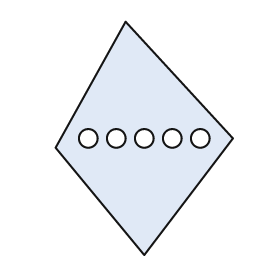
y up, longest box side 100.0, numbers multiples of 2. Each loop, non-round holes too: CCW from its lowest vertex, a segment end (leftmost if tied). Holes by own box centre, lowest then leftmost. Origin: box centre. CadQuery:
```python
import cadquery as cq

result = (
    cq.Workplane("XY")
    .moveTo(0.0, -50.0)
    .lineTo(38.0, 0.0)
    .lineTo(-8.0, 50.0)
    .lineTo(-38.0, -4.0)
    .close()
    .moveTo(-24.0, 0.0)
    .circle(4.0)
    .moveTo(-12.0, 0.0)
    .circle(4.0)
    .moveTo(0.0, 0.0)
    .circle(4.0)
    .moveTo(12.0, 0.0)
    .circle(4.0)
    .moveTo(24.0, 0.0)
    .circle(4.0)
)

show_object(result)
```